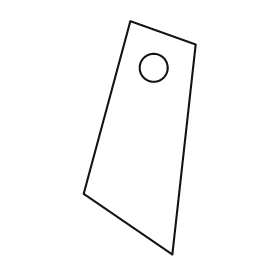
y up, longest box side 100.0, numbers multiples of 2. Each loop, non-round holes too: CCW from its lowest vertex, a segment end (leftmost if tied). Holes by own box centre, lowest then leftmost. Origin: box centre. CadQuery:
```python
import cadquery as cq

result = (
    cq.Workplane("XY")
    .moveTo(14.0, -50.0)
    .lineTo(24.0, 40.0)
    .lineTo(-4.0, 50.0)
    .lineTo(-24.0, -24.0)
    .close()
    .moveTo(6.0, 30.0)
    .circle(6.0)
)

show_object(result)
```